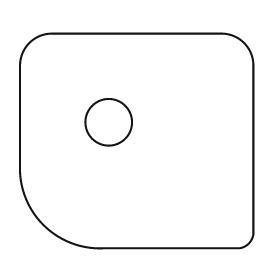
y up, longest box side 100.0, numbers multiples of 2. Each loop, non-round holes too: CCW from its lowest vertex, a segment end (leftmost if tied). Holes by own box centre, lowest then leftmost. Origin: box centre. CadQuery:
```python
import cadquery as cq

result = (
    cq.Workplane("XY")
    .moveTo(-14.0, -46.0)
    .lineTo(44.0, -46.0)
    .threePointArc((48.0, -44.0), (50.0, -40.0))
    .lineTo(50.0, 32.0)
    .threePointArc((46.0, 42.0), (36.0, 46.0))
    .lineTo(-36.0, 46.0)
    .threePointArc((-46.0, 42.0), (-50.0, 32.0))
    .lineTo(-50.0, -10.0)
    .threePointArc((-40.0, -36.0), (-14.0, -46.0))
    .close()
    .moveTo(-12.0, 8.0)
    .circle(10.0)
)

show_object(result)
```